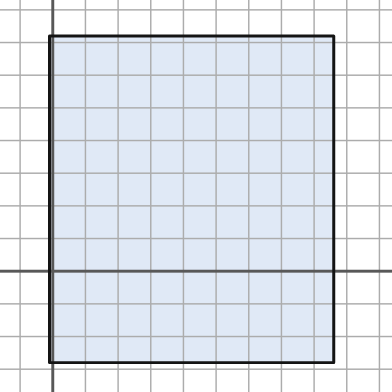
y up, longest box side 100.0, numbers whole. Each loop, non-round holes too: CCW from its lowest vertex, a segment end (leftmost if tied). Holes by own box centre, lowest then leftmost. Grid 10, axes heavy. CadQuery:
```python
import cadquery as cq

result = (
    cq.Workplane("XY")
    .moveTo(-1.0, -28.0)
    .lineTo(86.0, -28.0)
    .lineTo(86.0, 72.0)
    .lineTo(-1.0, 72.0)
    .close()
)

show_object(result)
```